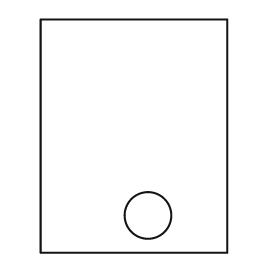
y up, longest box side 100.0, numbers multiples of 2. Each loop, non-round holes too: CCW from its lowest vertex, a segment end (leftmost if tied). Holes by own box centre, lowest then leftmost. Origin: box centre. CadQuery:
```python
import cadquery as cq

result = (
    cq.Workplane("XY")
    .moveTo(-40.0, -50.0)
    .lineTo(40.0, -50.0)
    .lineTo(40.0, 50.0)
    .lineTo(-40.0, 50.0)
    .close()
    .moveTo(6.0, -34.0)
    .circle(10.0)
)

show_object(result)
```